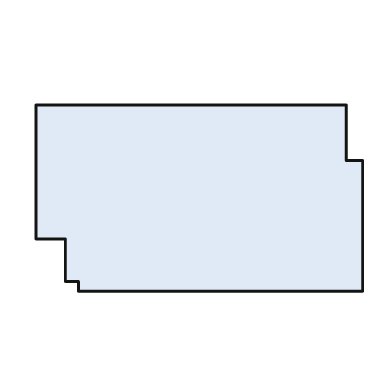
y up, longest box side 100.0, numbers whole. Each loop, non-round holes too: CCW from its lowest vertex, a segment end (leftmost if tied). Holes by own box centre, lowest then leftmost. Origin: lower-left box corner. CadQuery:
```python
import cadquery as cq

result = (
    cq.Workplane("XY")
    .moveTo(13.0, 0.0)
    .lineTo(100.0, 0.0)
    .lineTo(100.0, 40.0)
    .lineTo(95.0, 40.0)
    .lineTo(95.0, 57.0)
    .lineTo(0.0, 57.0)
    .lineTo(0.0, 16.0)
    .lineTo(9.0, 16.0)
    .lineTo(9.0, 3.0)
    .lineTo(13.0, 3.0)
    .close()
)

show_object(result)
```